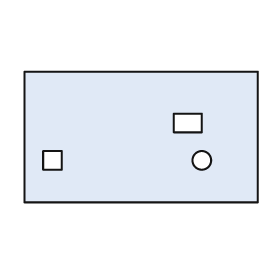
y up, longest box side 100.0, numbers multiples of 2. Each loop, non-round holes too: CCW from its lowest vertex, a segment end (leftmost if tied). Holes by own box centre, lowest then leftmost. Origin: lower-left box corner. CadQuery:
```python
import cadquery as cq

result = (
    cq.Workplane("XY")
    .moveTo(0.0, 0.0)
    .lineTo(100.0, 0.0)
    .lineTo(100.0, 56.0)
    .lineTo(0.0, 56.0)
    .close()
    .moveTo(8.0, 14.0)
    .lineTo(16.0, 14.0)
    .lineTo(16.0, 22.0)
    .lineTo(8.0, 22.0)
    .close()
    .moveTo(76.0, 18.0)
    .circle(4.0)
    .moveTo(64.0, 30.0)
    .lineTo(76.0, 30.0)
    .lineTo(76.0, 38.0)
    .lineTo(64.0, 38.0)
    .close()
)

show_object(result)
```